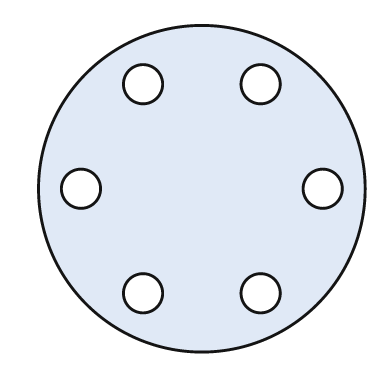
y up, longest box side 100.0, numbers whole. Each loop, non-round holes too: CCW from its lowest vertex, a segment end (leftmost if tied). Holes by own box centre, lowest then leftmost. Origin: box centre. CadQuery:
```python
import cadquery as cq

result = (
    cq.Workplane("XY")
    .moveTo(0.0, 0.0)
    .circle(50.0)
    .moveTo(-18.0, -32.0)
    .circle(6.0)
    .moveTo(18.0, -32.0)
    .circle(6.0)
    .moveTo(-37.0, 0.0)
    .circle(6.0)
    .moveTo(37.0, 0.0)
    .circle(6.0)
    .moveTo(-18.0, 32.0)
    .circle(6.0)
    .moveTo(18.0, 32.0)
    .circle(6.0)
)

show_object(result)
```